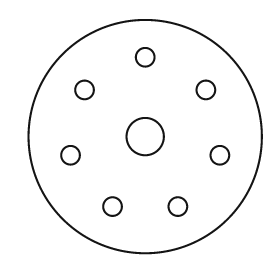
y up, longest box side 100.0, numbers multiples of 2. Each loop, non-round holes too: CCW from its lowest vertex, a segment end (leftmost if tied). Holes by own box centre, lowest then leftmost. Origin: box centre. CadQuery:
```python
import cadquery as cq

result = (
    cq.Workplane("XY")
    .moveTo(0.0, 0.0)
    .circle(50.0)
    .moveTo(-14.0, -30.0)
    .circle(4.0)
    .moveTo(14.0, -30.0)
    .circle(4.0)
    .moveTo(-32.0, -8.0)
    .circle(4.0)
    .moveTo(32.0, -8.0)
    .circle(4.0)
    .moveTo(0.0, 0.0)
    .circle(8.0)
    .moveTo(-26.0, 20.0)
    .circle(4.0)
    .moveTo(26.0, 20.0)
    .circle(4.0)
    .moveTo(0.0, 34.0)
    .circle(4.0)
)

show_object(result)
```